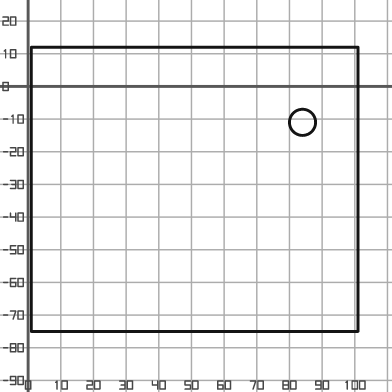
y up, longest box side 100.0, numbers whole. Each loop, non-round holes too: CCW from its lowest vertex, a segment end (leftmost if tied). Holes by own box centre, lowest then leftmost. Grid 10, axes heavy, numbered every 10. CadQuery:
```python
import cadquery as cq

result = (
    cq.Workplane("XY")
    .moveTo(1.0, -75.0)
    .lineTo(101.0, -75.0)
    .lineTo(101.0, 12.0)
    .lineTo(1.0, 12.0)
    .close()
    .moveTo(84.0, -11.0)
    .circle(4.0)
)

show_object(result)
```